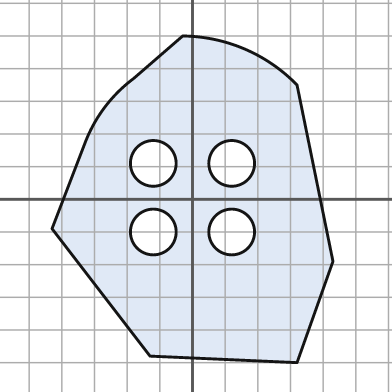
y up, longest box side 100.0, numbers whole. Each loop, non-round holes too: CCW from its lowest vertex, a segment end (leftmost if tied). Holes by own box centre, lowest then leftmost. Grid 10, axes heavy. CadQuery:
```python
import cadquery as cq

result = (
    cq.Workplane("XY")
    .moveTo(32.0, -50.0)
    .lineTo(43.0, -19.0)
    .lineTo(32.0, 35.0)
    .threePointArc((16.0, 46.0), (-3.0, 50.0))
    .lineTo(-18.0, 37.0)
    .threePointArc((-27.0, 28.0), (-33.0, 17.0))
    .lineTo(-43.0, -9.0)
    .lineTo(-13.0, -48.0)
    .close()
    .moveTo(-12.0, -10.0)
    .circle(7.0)
    .moveTo(12.0, -10.0)
    .circle(7.0)
    .moveTo(-12.0, 11.0)
    .circle(7.0)
    .moveTo(12.0, 11.0)
    .circle(7.0)
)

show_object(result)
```